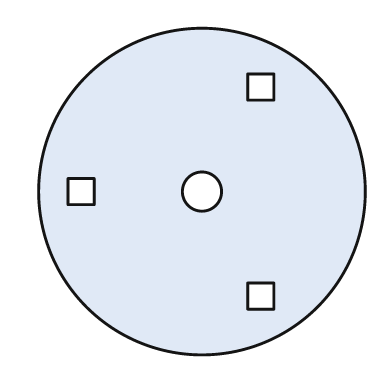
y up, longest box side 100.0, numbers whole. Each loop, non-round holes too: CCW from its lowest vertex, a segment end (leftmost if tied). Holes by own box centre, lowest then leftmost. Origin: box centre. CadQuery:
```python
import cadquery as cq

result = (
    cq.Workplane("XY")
    .moveTo(0.0, 0.0)
    .circle(50.0)
    .moveTo(14.0, -36.0)
    .lineTo(22.0, -36.0)
    .lineTo(22.0, -28.0)
    .lineTo(14.0, -28.0)
    .close()
    .moveTo(-41.0, -4.0)
    .lineTo(-33.0, -4.0)
    .lineTo(-33.0, 4.0)
    .lineTo(-41.0, 4.0)
    .close()
    .moveTo(0.0, 0.0)
    .circle(6.0)
    .moveTo(14.0, 28.0)
    .lineTo(22.0, 28.0)
    .lineTo(22.0, 36.0)
    .lineTo(14.0, 36.0)
    .close()
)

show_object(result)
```